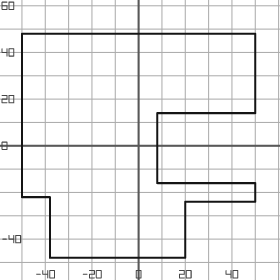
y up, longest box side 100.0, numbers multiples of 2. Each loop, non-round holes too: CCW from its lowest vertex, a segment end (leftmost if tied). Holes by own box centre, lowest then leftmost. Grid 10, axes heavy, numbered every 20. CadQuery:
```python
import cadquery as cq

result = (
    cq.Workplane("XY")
    .moveTo(-38.0, -48.0)
    .lineTo(20.0, -48.0)
    .lineTo(20.0, -24.0)
    .lineTo(50.0, -24.0)
    .lineTo(50.0, -16.0)
    .lineTo(8.0, -16.0)
    .lineTo(8.0, 14.0)
    .lineTo(50.0, 14.0)
    .lineTo(50.0, 48.0)
    .lineTo(-50.0, 48.0)
    .lineTo(-50.0, -22.0)
    .lineTo(-38.0, -22.0)
    .close()
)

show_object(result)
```